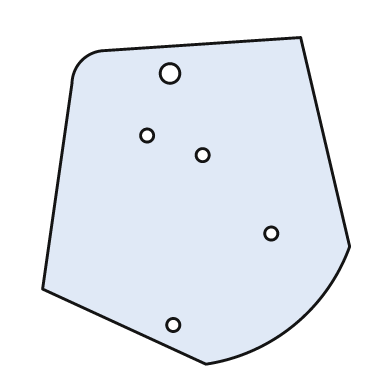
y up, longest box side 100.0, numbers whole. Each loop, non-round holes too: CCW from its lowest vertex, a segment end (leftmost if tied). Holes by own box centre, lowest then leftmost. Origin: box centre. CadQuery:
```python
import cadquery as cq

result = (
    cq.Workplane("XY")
    .moveTo(3.0, -50.0)
    .threePointArc((30.0, -38.0), (47.0, -14.0))
    .lineTo(32.0, 50.0)
    .lineTo(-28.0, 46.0)
    .threePointArc((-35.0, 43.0), (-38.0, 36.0))
    .lineTo(-47.0, -27.0)
    .close()
    .moveTo(-7.0, -38.0)
    .circle(2.0)
    .moveTo(23.0, -10.0)
    .circle(2.0)
    .moveTo(2.0, 14.0)
    .circle(2.0)
    .moveTo(-15.0, 20.0)
    .circle(2.0)
    .moveTo(-8.0, 39.0)
    .circle(3.0)
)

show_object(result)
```